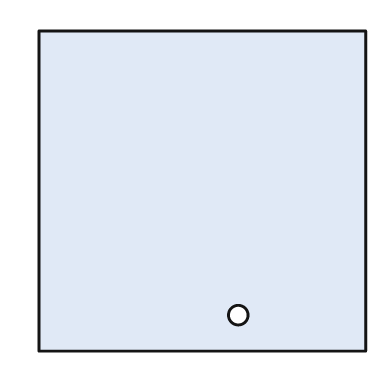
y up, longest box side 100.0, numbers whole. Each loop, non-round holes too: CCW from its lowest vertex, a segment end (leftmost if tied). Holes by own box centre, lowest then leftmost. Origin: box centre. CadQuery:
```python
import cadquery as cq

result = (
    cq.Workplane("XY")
    .moveTo(-50.0, -49.0)
    .lineTo(50.0, -49.0)
    .lineTo(50.0, 49.0)
    .lineTo(-50.0, 49.0)
    .close()
    .moveTo(11.0, -38.0)
    .circle(3.0)
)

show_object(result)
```